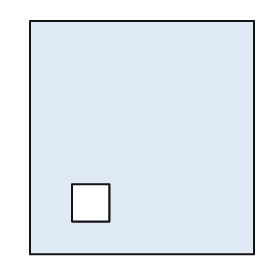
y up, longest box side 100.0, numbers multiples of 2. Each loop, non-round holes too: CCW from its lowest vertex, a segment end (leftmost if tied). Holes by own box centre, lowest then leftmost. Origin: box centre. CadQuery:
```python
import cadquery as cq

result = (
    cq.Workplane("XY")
    .moveTo(-48.0, -50.0)
    .lineTo(48.0, -50.0)
    .lineTo(48.0, 50.0)
    .lineTo(-48.0, 50.0)
    .close()
    .moveTo(-30.0, -36.0)
    .lineTo(-14.0, -36.0)
    .lineTo(-14.0, -20.0)
    .lineTo(-30.0, -20.0)
    .close()
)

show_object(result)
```